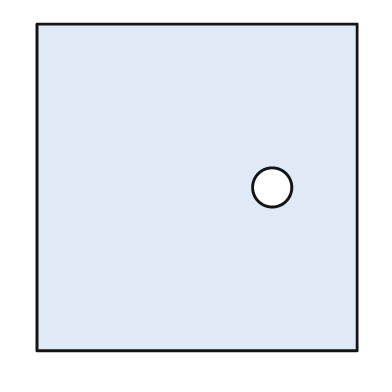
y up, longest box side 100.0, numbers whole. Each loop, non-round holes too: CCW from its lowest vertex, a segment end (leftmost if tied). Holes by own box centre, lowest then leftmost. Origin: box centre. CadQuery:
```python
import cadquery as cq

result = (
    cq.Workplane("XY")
    .moveTo(-49.0, -50.0)
    .lineTo(49.0, -50.0)
    .lineTo(49.0, 50.0)
    .lineTo(-49.0, 50.0)
    .close()
    .moveTo(23.0, 0.0)
    .circle(6.0)
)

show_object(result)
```